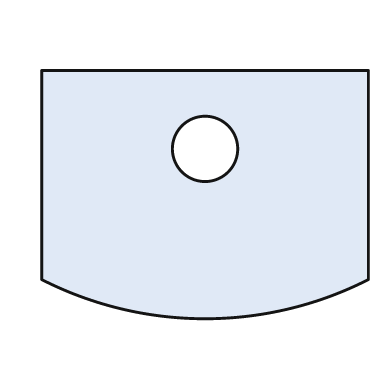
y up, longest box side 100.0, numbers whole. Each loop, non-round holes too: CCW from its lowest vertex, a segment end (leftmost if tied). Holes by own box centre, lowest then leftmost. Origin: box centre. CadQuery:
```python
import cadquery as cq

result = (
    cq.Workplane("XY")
    .moveTo(-50.0, -26.0)
    .threePointArc((0.0, -38.0), (50.0, -26.0))
    .lineTo(50.0, 38.0)
    .lineTo(-50.0, 38.0)
    .close()
    .moveTo(0.0, 14.0)
    .circle(10.0)
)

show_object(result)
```